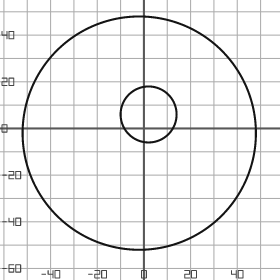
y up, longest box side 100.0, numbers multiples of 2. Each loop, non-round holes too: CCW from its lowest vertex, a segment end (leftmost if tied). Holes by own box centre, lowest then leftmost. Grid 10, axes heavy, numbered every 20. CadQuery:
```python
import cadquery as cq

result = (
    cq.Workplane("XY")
    .moveTo(-2.0, -2.0)
    .circle(50.0)
    .moveTo(2.0, 6.0)
    .circle(12.0)
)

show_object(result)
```